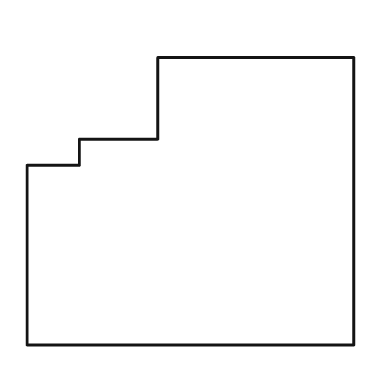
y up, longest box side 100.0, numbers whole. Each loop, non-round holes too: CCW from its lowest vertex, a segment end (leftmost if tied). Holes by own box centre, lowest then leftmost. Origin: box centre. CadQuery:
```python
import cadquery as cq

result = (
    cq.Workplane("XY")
    .moveTo(-50.0, -44.0)
    .lineTo(50.0, -44.0)
    .lineTo(50.0, 44.0)
    .lineTo(-10.0, 44.0)
    .lineTo(-10.0, 19.0)
    .lineTo(-34.0, 19.0)
    .lineTo(-34.0, 11.0)
    .lineTo(-50.0, 11.0)
    .close()
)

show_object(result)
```